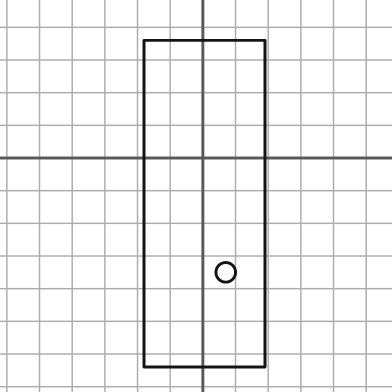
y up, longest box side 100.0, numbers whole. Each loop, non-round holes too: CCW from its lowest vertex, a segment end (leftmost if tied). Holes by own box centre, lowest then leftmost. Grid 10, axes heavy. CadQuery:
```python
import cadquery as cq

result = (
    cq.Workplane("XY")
    .moveTo(-18.0, -64.0)
    .lineTo(19.0, -64.0)
    .lineTo(19.0, 36.0)
    .lineTo(-18.0, 36.0)
    .close()
    .moveTo(7.0, -35.0)
    .circle(3.0)
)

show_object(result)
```